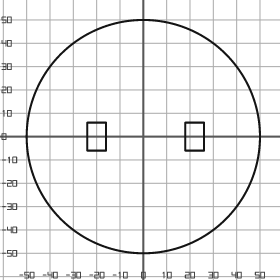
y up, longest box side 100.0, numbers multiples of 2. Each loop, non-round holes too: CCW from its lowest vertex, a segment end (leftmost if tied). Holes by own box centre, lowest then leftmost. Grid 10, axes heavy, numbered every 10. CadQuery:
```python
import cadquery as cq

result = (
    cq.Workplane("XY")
    .moveTo(0.0, 0.0)
    .circle(50.0)
    .moveTo(-24.0, -6.0)
    .lineTo(-16.0, -6.0)
    .lineTo(-16.0, 6.0)
    .lineTo(-24.0, 6.0)
    .close()
    .moveTo(18.0, -6.0)
    .lineTo(26.0, -6.0)
    .lineTo(26.0, 6.0)
    .lineTo(18.0, 6.0)
    .close()
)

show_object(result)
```